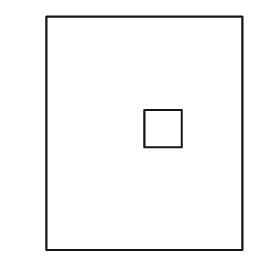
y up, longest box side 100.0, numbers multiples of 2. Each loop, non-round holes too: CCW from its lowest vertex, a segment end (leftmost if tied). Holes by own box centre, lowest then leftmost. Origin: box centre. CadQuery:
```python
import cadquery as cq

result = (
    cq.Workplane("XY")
    .moveTo(-42.0, -50.0)
    .lineTo(42.0, -50.0)
    .lineTo(42.0, 50.0)
    .lineTo(-42.0, 50.0)
    .close()
    .moveTo(0.0, -6.0)
    .lineTo(16.0, -6.0)
    .lineTo(16.0, 10.0)
    .lineTo(0.0, 10.0)
    .close()
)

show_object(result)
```